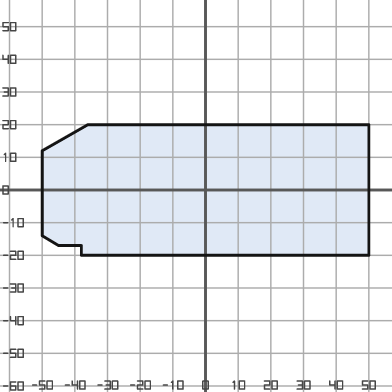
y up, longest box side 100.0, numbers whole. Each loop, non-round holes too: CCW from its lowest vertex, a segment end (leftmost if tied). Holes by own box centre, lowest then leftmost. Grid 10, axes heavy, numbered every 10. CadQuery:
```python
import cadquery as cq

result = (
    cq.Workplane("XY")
    .moveTo(-38.0, -20.0)
    .lineTo(50.0, -20.0)
    .lineTo(50.0, 20.0)
    .lineTo(-36.0, 20.0)
    .lineTo(-50.0, 12.0)
    .lineTo(-50.0, -14.0)
    .lineTo(-45.0, -17.0)
    .lineTo(-38.0, -17.0)
    .close()
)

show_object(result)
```